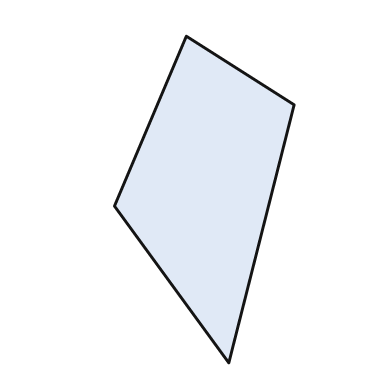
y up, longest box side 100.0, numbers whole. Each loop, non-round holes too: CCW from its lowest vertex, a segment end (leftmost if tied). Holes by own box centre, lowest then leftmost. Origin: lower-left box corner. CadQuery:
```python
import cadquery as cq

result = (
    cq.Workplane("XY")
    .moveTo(35.0, 0.0)
    .lineTo(55.0, 79.0)
    .lineTo(22.0, 100.0)
    .lineTo(0.0, 48.0)
    .close()
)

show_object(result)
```